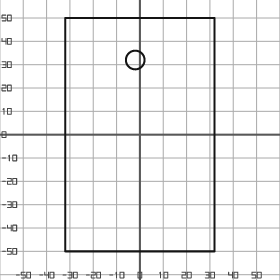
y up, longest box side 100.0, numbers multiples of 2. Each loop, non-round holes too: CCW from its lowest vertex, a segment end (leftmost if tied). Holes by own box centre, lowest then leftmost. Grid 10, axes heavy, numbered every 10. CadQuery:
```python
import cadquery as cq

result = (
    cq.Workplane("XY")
    .moveTo(-32.0, -50.0)
    .lineTo(32.0, -50.0)
    .lineTo(32.0, 50.0)
    .lineTo(-32.0, 50.0)
    .close()
    .moveTo(-2.0, 32.0)
    .circle(4.0)
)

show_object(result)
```